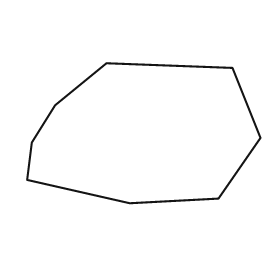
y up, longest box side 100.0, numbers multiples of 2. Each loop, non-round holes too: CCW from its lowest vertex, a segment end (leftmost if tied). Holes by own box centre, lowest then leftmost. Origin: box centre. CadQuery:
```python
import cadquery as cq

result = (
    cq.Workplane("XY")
    .moveTo(-6.0, -30.0)
    .lineTo(32.0, -28.0)
    .lineTo(50.0, -2.0)
    .lineTo(38.0, 28.0)
    .lineTo(-16.0, 30.0)
    .lineTo(-38.0, 12.0)
    .lineTo(-48.0, -4.0)
    .lineTo(-50.0, -20.0)
    .close()
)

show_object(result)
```